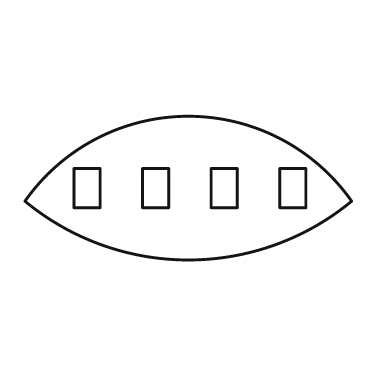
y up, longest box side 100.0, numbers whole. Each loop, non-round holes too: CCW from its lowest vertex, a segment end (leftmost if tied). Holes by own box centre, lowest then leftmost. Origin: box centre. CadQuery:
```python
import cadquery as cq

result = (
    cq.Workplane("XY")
    .moveTo(-50.0, -4.0)
    .threePointArc((0.0, -22.0), (50.0, -4.0))
    .threePointArc((0.0, 22.0), (-50.0, -4.0))
    .close()
    .moveTo(-35.0, -6.0)
    .lineTo(-27.0, -6.0)
    .lineTo(-27.0, 6.0)
    .lineTo(-35.0, 6.0)
    .close()
    .moveTo(-14.0, -6.0)
    .lineTo(-6.0, -6.0)
    .lineTo(-6.0, 6.0)
    .lineTo(-14.0, 6.0)
    .close()
    .moveTo(7.0, -6.0)
    .lineTo(15.0, -6.0)
    .lineTo(15.0, 6.0)
    .lineTo(7.0, 6.0)
    .close()
    .moveTo(28.0, -6.0)
    .lineTo(36.0, -6.0)
    .lineTo(36.0, 6.0)
    .lineTo(28.0, 6.0)
    .close()
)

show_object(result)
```